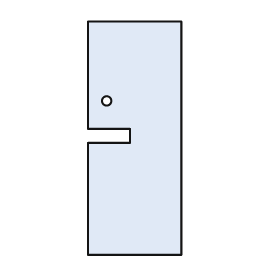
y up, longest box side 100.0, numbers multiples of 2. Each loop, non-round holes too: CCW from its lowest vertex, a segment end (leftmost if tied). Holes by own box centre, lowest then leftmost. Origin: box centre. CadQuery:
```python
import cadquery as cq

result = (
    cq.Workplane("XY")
    .moveTo(-20.0, -50.0)
    .lineTo(20.0, -50.0)
    .lineTo(20.0, 50.0)
    .lineTo(-20.0, 50.0)
    .lineTo(-20.0, 4.0)
    .lineTo(-2.0, 4.0)
    .lineTo(-2.0, -2.0)
    .lineTo(-20.0, -2.0)
    .close()
    .moveTo(-12.0, 16.0)
    .circle(2.0)
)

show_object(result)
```